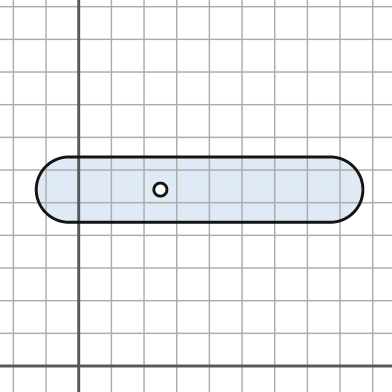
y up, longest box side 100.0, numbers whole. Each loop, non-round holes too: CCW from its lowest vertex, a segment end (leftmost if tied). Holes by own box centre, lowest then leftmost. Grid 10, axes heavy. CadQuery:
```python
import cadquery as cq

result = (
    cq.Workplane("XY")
    .moveTo(-3.0, 44.0)
    .lineTo(77.0, 44.0)
    .threePointArc((87.0, 54.0), (77.0, 64.0))
    .lineTo(-3.0, 64.0)
    .threePointArc((-13.0, 54.0), (-3.0, 44.0))
    .close()
    .moveTo(25.0, 54.0)
    .circle(2.0)
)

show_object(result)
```